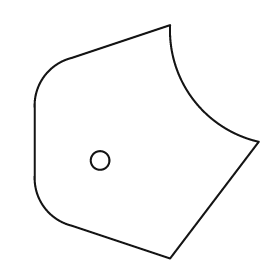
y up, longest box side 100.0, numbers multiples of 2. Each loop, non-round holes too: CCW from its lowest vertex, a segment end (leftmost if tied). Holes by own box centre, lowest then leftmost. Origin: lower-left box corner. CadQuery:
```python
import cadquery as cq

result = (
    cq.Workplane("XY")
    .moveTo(58.0, 0.0)
    .lineTo(96.0, 50.0)
    .threePointArc((68.0, 68.0), (58.0, 100.0))
    .lineTo(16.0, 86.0)
    .threePointArc((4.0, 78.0), (0.0, 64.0))
    .lineTo(0.0, 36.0)
    .threePointArc((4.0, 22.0), (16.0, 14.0))
    .close()
    .moveTo(28.0, 42.0)
    .circle(4.0)
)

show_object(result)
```